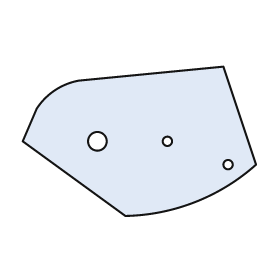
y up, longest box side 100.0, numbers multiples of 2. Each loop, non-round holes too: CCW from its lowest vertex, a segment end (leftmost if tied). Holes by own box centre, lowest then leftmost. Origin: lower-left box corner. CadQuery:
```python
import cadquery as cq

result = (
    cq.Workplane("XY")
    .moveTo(44.0, 0.0)
    .threePointArc((74.0, 6.0), (100.0, 22.0))
    .lineTo(86.0, 64.0)
    .lineTo(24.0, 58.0)
    .threePointArc((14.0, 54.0), (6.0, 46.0))
    .lineTo(0.0, 32.0)
    .close()
    .moveTo(88.0, 22.0)
    .circle(2.0)
    .moveTo(32.0, 32.0)
    .circle(4.0)
    .moveTo(62.0, 32.0)
    .circle(2.0)
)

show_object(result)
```